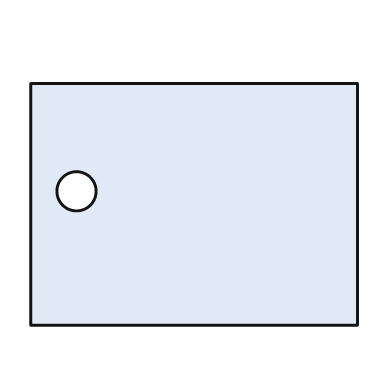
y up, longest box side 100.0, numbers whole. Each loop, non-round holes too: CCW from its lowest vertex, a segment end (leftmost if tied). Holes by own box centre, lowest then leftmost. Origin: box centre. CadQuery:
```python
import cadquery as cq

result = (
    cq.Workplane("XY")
    .moveTo(-50.0, -37.0)
    .lineTo(50.0, -37.0)
    .lineTo(50.0, 37.0)
    .lineTo(-50.0, 37.0)
    .close()
    .moveTo(-36.0, 4.0)
    .circle(6.0)
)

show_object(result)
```